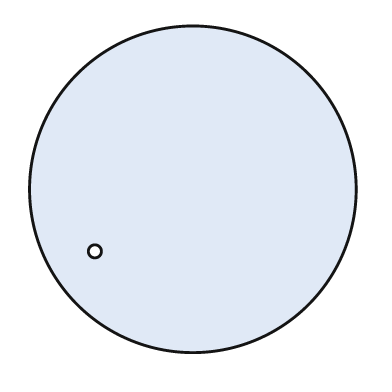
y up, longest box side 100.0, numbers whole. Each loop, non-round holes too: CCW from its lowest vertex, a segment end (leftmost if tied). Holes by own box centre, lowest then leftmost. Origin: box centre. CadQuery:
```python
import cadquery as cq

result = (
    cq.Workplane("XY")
    .moveTo(0.0, 0.0)
    .circle(50.0)
    .moveTo(-30.0, -19.0)
    .circle(2.0)
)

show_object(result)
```